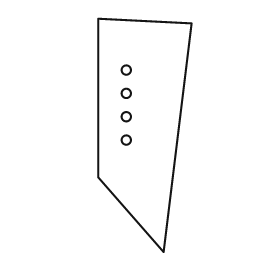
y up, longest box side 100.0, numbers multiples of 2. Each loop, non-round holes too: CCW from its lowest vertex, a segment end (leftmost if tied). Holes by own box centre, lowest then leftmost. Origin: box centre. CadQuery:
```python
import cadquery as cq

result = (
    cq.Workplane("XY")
    .moveTo(8.0, -50.0)
    .lineTo(20.0, 48.0)
    .lineTo(-20.0, 50.0)
    .lineTo(-20.0, -18.0)
    .close()
    .moveTo(-8.0, -2.0)
    .circle(2.0)
    .moveTo(-8.0, 8.0)
    .circle(2.0)
    .moveTo(-8.0, 18.0)
    .circle(2.0)
    .moveTo(-8.0, 28.0)
    .circle(2.0)
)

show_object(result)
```